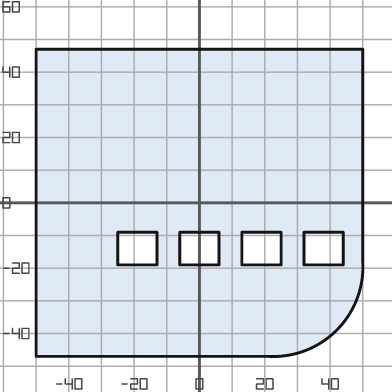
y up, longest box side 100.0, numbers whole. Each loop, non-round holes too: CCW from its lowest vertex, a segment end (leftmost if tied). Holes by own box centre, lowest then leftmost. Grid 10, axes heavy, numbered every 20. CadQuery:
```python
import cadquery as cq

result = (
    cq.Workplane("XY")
    .moveTo(-50.0, -47.0)
    .lineTo(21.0, -47.0)
    .threePointArc((42.0, -39.0), (50.0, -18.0))
    .lineTo(50.0, 47.0)
    .lineTo(-50.0, 47.0)
    .close()
    .moveTo(-25.0, -19.0)
    .lineTo(-13.0, -19.0)
    .lineTo(-13.0, -9.0)
    .lineTo(-25.0, -9.0)
    .close()
    .moveTo(-6.0, -19.0)
    .lineTo(6.0, -19.0)
    .lineTo(6.0, -9.0)
    .lineTo(-6.0, -9.0)
    .close()
    .moveTo(13.0, -19.0)
    .lineTo(25.0, -19.0)
    .lineTo(25.0, -9.0)
    .lineTo(13.0, -9.0)
    .close()
    .moveTo(32.0, -19.0)
    .lineTo(44.0, -19.0)
    .lineTo(44.0, -9.0)
    .lineTo(32.0, -9.0)
    .close()
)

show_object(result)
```